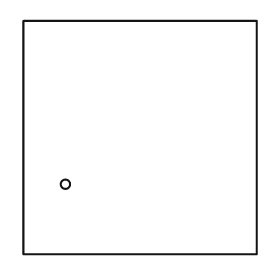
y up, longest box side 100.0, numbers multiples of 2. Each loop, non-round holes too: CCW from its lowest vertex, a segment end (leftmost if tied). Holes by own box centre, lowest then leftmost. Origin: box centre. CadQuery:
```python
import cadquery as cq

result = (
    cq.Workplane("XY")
    .moveTo(-50.0, -50.0)
    .lineTo(50.0, -50.0)
    .lineTo(50.0, 50.0)
    .lineTo(-50.0, 50.0)
    .close()
    .moveTo(-32.0, -20.0)
    .circle(2.0)
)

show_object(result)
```